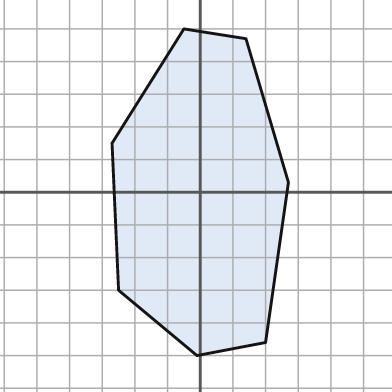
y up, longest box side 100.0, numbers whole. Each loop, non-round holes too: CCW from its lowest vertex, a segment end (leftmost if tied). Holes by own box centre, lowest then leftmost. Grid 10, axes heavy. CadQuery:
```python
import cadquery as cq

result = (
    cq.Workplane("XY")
    .moveTo(-1.0, -50.0)
    .lineTo(20.0, -46.0)
    .lineTo(27.0, 3.0)
    .lineTo(14.0, 47.0)
    .lineTo(-5.0, 50.0)
    .lineTo(-27.0, 15.0)
    .lineTo(-25.0, -30.0)
    .close()
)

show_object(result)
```